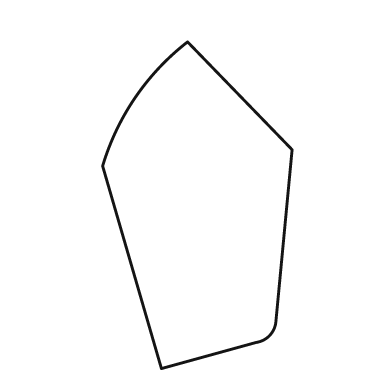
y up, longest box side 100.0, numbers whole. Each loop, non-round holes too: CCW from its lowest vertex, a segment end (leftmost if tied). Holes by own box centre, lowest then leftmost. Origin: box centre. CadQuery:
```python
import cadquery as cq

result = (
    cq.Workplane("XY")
    .moveTo(-11.0, -50.0)
    .lineTo(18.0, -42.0)
    .threePointArc((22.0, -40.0), (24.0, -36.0))
    .lineTo(29.0, 17.0)
    .lineTo(-3.0, 50.0)
    .threePointArc((-19.0, 33.0), (-29.0, 12.0))
    .close()
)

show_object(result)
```